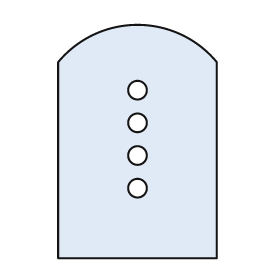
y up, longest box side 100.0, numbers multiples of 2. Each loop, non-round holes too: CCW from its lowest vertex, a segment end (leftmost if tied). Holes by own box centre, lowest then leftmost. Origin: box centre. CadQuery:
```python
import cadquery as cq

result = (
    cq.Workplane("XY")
    .moveTo(-34.0, -50.0)
    .lineTo(34.0, -50.0)
    .lineTo(34.0, 34.0)
    .threePointArc((0.0, 50.0), (-34.0, 34.0))
    .close()
    .moveTo(0.0, -20.0)
    .circle(4.0)
    .moveTo(0.0, -6.0)
    .circle(4.0)
    .moveTo(0.0, 8.0)
    .circle(4.0)
    .moveTo(0.0, 22.0)
    .circle(4.0)
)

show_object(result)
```